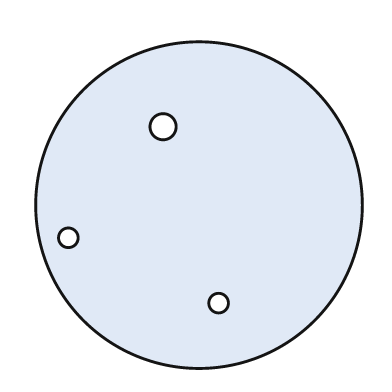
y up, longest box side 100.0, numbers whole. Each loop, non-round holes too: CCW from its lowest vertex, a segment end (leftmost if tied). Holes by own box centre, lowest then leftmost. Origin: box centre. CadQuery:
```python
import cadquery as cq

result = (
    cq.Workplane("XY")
    .moveTo(0.0, 0.0)
    .circle(50.0)
    .moveTo(6.0, -30.0)
    .circle(3.0)
    .moveTo(-40.0, -10.0)
    .circle(3.0)
    .moveTo(-11.0, 24.0)
    .circle(4.0)
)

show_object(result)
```